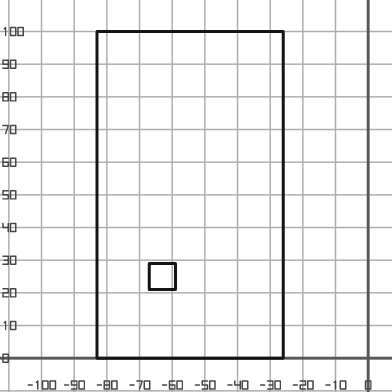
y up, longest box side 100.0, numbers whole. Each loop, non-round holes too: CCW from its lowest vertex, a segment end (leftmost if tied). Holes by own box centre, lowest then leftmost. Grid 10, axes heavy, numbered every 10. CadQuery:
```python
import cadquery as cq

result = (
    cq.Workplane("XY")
    .moveTo(-83.0, 0.0)
    .lineTo(-26.0, 0.0)
    .lineTo(-26.0, 100.0)
    .lineTo(-83.0, 100.0)
    .close()
    .moveTo(-67.0, 21.0)
    .lineTo(-59.0, 21.0)
    .lineTo(-59.0, 29.0)
    .lineTo(-67.0, 29.0)
    .close()
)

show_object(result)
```